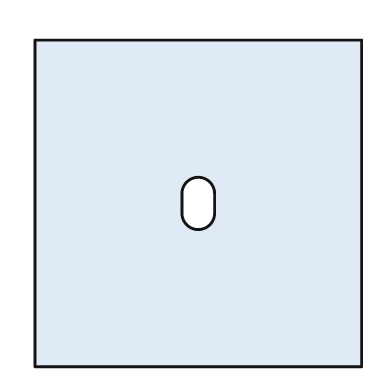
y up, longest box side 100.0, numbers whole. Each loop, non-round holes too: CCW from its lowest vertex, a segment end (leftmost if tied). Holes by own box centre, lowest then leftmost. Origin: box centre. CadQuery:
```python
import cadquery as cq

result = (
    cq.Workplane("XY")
    .moveTo(-50.0, -50.0)
    .lineTo(50.0, -50.0)
    .lineTo(50.0, 50.0)
    .lineTo(-50.0, 50.0)
    .close()
    .moveTo(-5.0, -3.0)
    .threePointArc((0.0, -8.0), (5.0, -3.0))
    .lineTo(5.0, 3.0)
    .threePointArc((0.0, 8.0), (-5.0, 3.0))
    .close()
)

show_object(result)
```